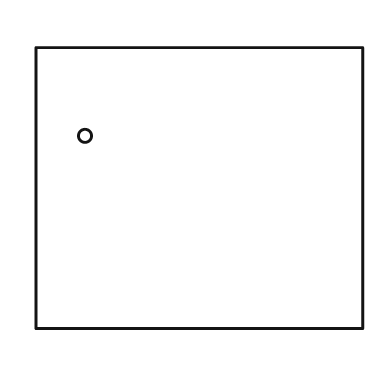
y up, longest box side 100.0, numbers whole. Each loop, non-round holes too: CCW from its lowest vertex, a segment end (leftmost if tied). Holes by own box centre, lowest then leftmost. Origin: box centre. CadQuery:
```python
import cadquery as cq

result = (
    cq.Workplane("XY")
    .moveTo(-50.0, -43.0)
    .lineTo(50.0, -43.0)
    .lineTo(50.0, 43.0)
    .lineTo(-50.0, 43.0)
    .close()
    .moveTo(-35.0, 16.0)
    .circle(2.0)
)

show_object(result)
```